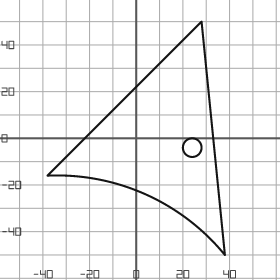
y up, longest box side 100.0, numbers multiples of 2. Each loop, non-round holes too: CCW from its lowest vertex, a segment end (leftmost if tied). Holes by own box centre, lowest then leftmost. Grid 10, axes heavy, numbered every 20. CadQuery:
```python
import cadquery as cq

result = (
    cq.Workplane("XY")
    .moveTo(38.0, -50.0)
    .lineTo(28.0, 50.0)
    .lineTo(-38.0, -16.0)
    .threePointArc((4.0, -24.0), (38.0, -50.0))
    .close()
    .moveTo(24.0, -4.0)
    .circle(4.0)
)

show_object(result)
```